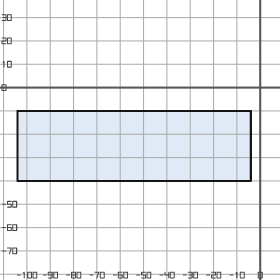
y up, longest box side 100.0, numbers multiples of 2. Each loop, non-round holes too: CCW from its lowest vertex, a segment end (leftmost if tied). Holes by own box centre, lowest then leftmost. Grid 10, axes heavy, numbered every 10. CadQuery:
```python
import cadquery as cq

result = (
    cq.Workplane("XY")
    .moveTo(-104.0, -40.0)
    .lineTo(-4.0, -40.0)
    .lineTo(-4.0, -10.0)
    .lineTo(-104.0, -10.0)
    .close()
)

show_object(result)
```